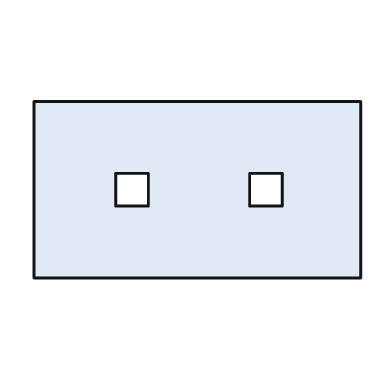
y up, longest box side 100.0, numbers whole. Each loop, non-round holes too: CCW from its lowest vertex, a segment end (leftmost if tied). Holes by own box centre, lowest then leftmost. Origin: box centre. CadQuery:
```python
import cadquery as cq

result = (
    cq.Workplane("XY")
    .moveTo(-50.0, -27.0)
    .lineTo(50.0, -27.0)
    .lineTo(50.0, 27.0)
    .lineTo(-50.0, 27.0)
    .close()
    .moveTo(-25.0, -5.0)
    .lineTo(-15.0, -5.0)
    .lineTo(-15.0, 5.0)
    .lineTo(-25.0, 5.0)
    .close()
    .moveTo(16.0, -5.0)
    .lineTo(26.0, -5.0)
    .lineTo(26.0, 5.0)
    .lineTo(16.0, 5.0)
    .close()
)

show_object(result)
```